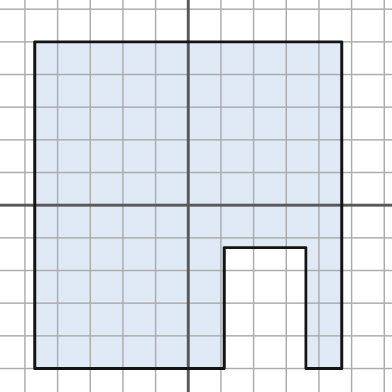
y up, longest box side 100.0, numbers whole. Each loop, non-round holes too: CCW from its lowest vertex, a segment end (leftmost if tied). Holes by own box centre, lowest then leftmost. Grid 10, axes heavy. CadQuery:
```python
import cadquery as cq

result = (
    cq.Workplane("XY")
    .moveTo(-47.0, -50.0)
    .lineTo(11.0, -50.0)
    .lineTo(11.0, -13.0)
    .lineTo(36.0, -13.0)
    .lineTo(36.0, -50.0)
    .lineTo(47.0, -50.0)
    .lineTo(47.0, 50.0)
    .lineTo(-47.0, 50.0)
    .close()
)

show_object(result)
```